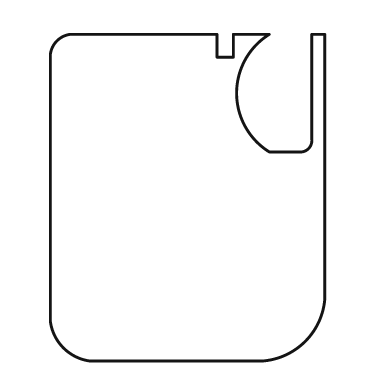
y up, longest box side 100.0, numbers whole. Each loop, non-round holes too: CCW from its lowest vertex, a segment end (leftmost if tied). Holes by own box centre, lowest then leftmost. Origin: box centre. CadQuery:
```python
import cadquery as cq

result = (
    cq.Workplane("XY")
    .moveTo(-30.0, -50.0)
    .lineTo(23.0, -50.0)
    .threePointArc((36.0, -44.0), (42.0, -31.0))
    .lineTo(42.0, 50.0)
    .lineTo(38.0, 50.0)
    .lineTo(38.0, 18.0)
    .threePointArc((37.0, 15.0), (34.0, 14.0))
    .lineTo(25.0, 14.0)
    .threePointArc((15.0, 32.0), (25.0, 50.0))
    .lineTo(14.0, 50.0)
    .lineTo(14.0, 43.0)
    .lineTo(9.0, 43.0)
    .lineTo(9.0, 50.0)
    .lineTo(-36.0, 50.0)
    .threePointArc((-40.0, 48.0), (-42.0, 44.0))
    .lineTo(-42.0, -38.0)
    .threePointArc((-38.0, -46.0), (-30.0, -50.0))
    .close()
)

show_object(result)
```